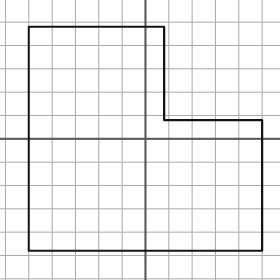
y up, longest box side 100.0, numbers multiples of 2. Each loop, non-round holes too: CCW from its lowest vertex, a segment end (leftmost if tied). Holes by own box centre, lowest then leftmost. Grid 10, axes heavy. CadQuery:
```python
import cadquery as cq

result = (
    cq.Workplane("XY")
    .moveTo(-50.0, -48.0)
    .lineTo(50.0, -48.0)
    .lineTo(50.0, 8.0)
    .lineTo(8.0, 8.0)
    .lineTo(8.0, 48.0)
    .lineTo(-50.0, 48.0)
    .close()
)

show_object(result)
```